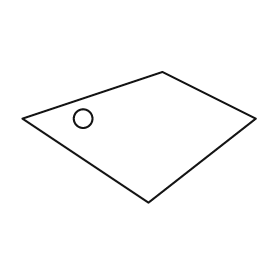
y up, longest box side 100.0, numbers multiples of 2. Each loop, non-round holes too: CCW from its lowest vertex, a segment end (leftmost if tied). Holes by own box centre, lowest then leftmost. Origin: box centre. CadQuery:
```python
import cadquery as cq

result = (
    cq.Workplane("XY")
    .moveTo(4.0, -28.0)
    .lineTo(50.0, 8.0)
    .lineTo(10.0, 28.0)
    .lineTo(-50.0, 8.0)
    .close()
    .moveTo(-24.0, 8.0)
    .circle(4.0)
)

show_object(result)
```